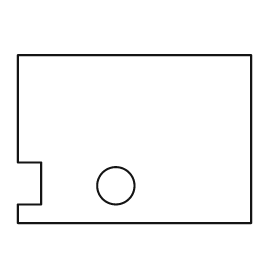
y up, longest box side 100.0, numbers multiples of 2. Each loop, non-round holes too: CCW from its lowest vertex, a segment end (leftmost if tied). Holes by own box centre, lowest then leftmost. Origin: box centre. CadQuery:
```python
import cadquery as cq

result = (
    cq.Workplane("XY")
    .moveTo(-50.0, -36.0)
    .lineTo(50.0, -36.0)
    .lineTo(50.0, 36.0)
    .lineTo(-50.0, 36.0)
    .lineTo(-50.0, -10.0)
    .lineTo(-40.0, -10.0)
    .lineTo(-40.0, -28.0)
    .lineTo(-50.0, -28.0)
    .close()
    .moveTo(-8.0, -20.0)
    .circle(8.0)
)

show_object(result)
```